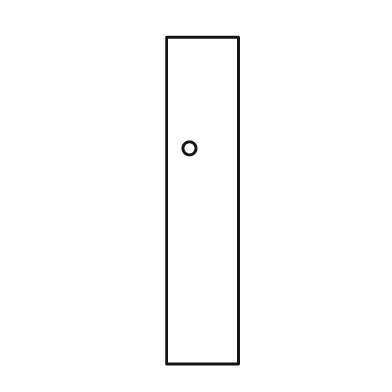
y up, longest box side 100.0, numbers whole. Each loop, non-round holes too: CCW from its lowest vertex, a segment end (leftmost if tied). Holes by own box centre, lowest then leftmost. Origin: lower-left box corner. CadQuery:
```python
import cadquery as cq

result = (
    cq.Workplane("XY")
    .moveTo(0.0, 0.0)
    .lineTo(22.0, 0.0)
    .lineTo(22.0, 100.0)
    .lineTo(0.0, 100.0)
    .close()
    .moveTo(7.0, 66.0)
    .circle(2.0)
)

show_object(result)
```